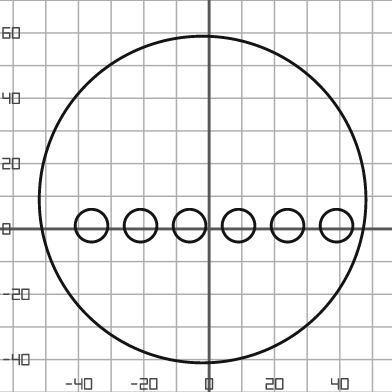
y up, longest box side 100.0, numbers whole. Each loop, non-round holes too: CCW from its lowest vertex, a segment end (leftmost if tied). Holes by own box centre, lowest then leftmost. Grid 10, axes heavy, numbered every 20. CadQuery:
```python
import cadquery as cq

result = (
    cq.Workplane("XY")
    .moveTo(-2.0, 9.0)
    .circle(50.0)
    .moveTo(-36.0, 1.0)
    .circle(5.0)
    .moveTo(-21.0, 1.0)
    .circle(5.0)
    .moveTo(-6.0, 1.0)
    .circle(5.0)
    .moveTo(9.0, 1.0)
    .circle(5.0)
    .moveTo(24.0, 1.0)
    .circle(5.0)
    .moveTo(39.0, 1.0)
    .circle(5.0)
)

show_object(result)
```